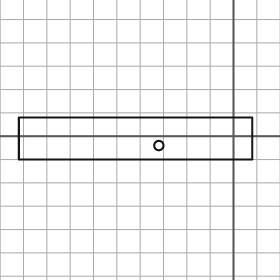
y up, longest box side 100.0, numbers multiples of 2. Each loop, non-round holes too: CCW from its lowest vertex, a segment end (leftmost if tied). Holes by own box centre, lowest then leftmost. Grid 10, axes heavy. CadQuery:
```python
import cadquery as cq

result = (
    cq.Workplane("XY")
    .moveTo(-92.0, -10.0)
    .lineTo(8.0, -10.0)
    .lineTo(8.0, 8.0)
    .lineTo(-92.0, 8.0)
    .close()
    .moveTo(-32.0, -4.0)
    .circle(2.0)
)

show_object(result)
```